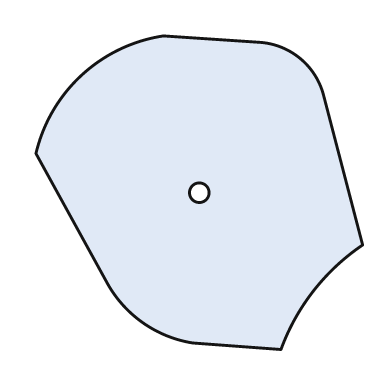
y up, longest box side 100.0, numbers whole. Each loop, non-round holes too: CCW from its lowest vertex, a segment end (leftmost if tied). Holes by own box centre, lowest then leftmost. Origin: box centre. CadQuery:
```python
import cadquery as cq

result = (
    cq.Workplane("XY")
    .moveTo(25.0, -48.0)
    .threePointArc((35.0, -30.0), (50.0, -16.0))
    .lineTo(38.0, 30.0)
    .threePointArc((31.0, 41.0), (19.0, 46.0))
    .lineTo(-11.0, 48.0)
    .threePointArc((-36.0, 36.0), (-50.0, 12.0))
    .lineTo(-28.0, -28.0)
    .threePointArc((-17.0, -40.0), (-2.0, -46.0))
    .close()
    .moveTo(0.0, 0.0)
    .circle(3.0)
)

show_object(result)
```